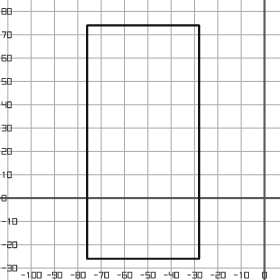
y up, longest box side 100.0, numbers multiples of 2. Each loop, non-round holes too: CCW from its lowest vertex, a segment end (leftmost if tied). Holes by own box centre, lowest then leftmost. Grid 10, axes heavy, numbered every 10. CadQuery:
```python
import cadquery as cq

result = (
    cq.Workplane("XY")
    .moveTo(-76.0, -26.0)
    .lineTo(-28.0, -26.0)
    .lineTo(-28.0, 74.0)
    .lineTo(-76.0, 74.0)
    .close()
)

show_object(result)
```